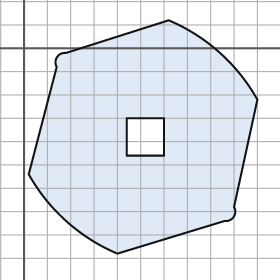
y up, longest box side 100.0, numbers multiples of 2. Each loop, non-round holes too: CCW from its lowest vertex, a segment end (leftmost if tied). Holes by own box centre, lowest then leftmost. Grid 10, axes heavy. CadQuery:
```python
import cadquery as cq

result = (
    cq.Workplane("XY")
    .moveTo(40.0, -88.0)
    .lineTo(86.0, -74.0)
    .threePointArc((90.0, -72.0), (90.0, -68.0))
    .lineTo(100.0, -22.0)
    .threePointArc((84.0, -2.0), (62.0, 12.0))
    .lineTo(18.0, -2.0)
    .threePointArc((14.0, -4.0), (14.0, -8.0))
    .lineTo(2.0, -54.0)
    .threePointArc((18.0, -74.0), (40.0, -88.0))
    .close()
    .moveTo(44.0, -46.0)
    .lineTo(60.0, -46.0)
    .lineTo(60.0, -30.0)
    .lineTo(44.0, -30.0)
    .close()
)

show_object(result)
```